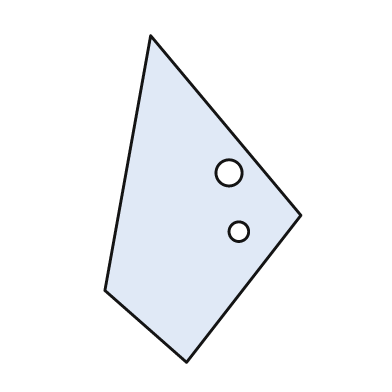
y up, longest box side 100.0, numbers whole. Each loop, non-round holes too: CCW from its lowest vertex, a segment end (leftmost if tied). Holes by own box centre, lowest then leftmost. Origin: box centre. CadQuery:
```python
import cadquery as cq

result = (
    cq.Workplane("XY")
    .moveTo(-5.0, -50.0)
    .lineTo(30.0, -5.0)
    .lineTo(-16.0, 50.0)
    .lineTo(-30.0, -28.0)
    .close()
    .moveTo(11.0, -10.0)
    .circle(3.0)
    .moveTo(8.0, 8.0)
    .circle(4.0)
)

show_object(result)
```